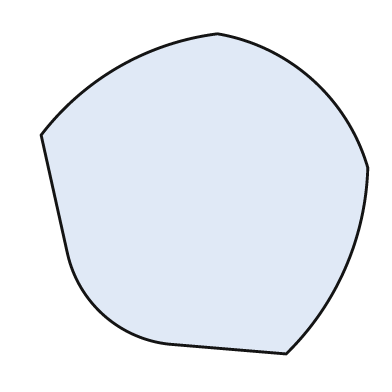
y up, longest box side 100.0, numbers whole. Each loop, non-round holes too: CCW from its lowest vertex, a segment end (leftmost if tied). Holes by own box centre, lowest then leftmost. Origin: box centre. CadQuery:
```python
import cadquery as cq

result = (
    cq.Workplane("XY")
    .moveTo(25.0, -49.0)
    .threePointArc((43.0, -23.0), (50.0, 8.0))
    .threePointArc((33.0, 35.0), (4.0, 49.0))
    .threePointArc((-26.0, 39.0), (-50.0, 18.0))
    .lineTo(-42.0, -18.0)
    .threePointArc((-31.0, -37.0), (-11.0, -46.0))
    .close()
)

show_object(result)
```